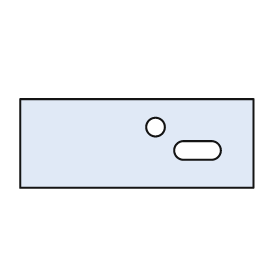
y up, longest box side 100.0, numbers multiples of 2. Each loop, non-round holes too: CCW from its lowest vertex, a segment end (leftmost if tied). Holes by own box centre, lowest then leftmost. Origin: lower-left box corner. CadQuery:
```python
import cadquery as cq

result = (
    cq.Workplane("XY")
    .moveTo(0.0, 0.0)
    .lineTo(100.0, 0.0)
    .lineTo(100.0, 38.0)
    .lineTo(0.0, 38.0)
    .close()
    .moveTo(70.0, 12.0)
    .lineTo(82.0, 12.0)
    .threePointArc((86.0, 16.0), (82.0, 20.0))
    .lineTo(70.0, 20.0)
    .threePointArc((66.0, 16.0), (70.0, 12.0))
    .close()
    .moveTo(58.0, 26.0)
    .circle(4.0)
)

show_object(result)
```